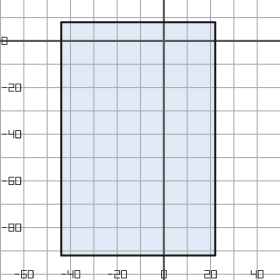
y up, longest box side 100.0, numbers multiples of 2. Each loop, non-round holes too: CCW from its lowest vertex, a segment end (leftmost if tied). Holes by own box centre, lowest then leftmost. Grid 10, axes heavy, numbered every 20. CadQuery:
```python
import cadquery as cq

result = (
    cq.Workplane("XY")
    .moveTo(-44.0, -92.0)
    .lineTo(22.0, -92.0)
    .lineTo(22.0, 8.0)
    .lineTo(-44.0, 8.0)
    .close()
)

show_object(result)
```